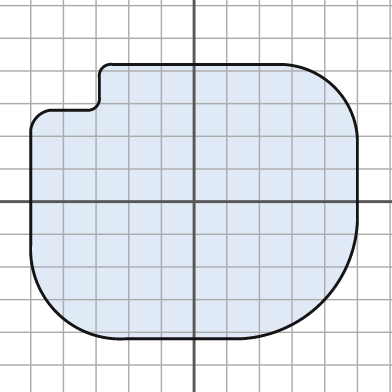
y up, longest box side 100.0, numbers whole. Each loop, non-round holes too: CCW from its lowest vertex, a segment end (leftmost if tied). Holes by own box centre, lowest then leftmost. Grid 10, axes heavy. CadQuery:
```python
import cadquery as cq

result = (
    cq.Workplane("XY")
    .moveTo(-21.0, -42.0)
    .lineTo(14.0, -42.0)
    .threePointArc((39.0, -31.0), (50.0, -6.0))
    .lineTo(50.0, 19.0)
    .threePointArc((43.0, 35.0), (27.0, 42.0))
    .lineTo(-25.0, 42.0)
    .threePointArc((-28.0, 41.0), (-29.0, 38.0))
    .lineTo(-29.0, 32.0)
    .threePointArc((-30.0, 29.0), (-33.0, 28.0))
    .lineTo(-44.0, 28.0)
    .threePointArc((-48.0, 26.0), (-50.0, 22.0))
    .lineTo(-50.0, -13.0)
    .threePointArc((-42.0, -34.0), (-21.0, -42.0))
    .close()
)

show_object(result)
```